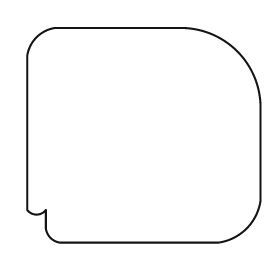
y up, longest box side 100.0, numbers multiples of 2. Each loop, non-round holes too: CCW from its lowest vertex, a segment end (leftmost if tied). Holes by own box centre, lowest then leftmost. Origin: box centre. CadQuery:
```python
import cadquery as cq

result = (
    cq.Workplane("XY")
    .moveTo(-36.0, -46.0)
    .lineTo(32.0, -46.0)
    .threePointArc((44.0, -40.0), (50.0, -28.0))
    .lineTo(50.0, 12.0)
    .threePointArc((40.0, 36.0), (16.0, 46.0))
    .lineTo(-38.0, 46.0)
    .threePointArc((-46.0, 42.0), (-50.0, 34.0))
    .lineTo(-50.0, -32.0)
    .threePointArc((-46.0, -34.0), (-42.0, -32.0))
    .lineTo(-42.0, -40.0)
    .threePointArc((-40.0, -44.0), (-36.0, -46.0))
    .close()
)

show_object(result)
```